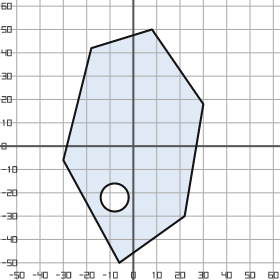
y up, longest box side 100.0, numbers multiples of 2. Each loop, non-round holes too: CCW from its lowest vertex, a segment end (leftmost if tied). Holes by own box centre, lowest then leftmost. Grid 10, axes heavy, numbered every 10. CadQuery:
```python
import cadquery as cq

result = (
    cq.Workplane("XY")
    .moveTo(-6.0, -50.0)
    .lineTo(22.0, -30.0)
    .lineTo(30.0, 18.0)
    .lineTo(8.0, 50.0)
    .lineTo(-18.0, 42.0)
    .lineTo(-30.0, -6.0)
    .close()
    .moveTo(-8.0, -22.0)
    .circle(6.0)
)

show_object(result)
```